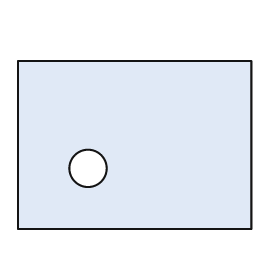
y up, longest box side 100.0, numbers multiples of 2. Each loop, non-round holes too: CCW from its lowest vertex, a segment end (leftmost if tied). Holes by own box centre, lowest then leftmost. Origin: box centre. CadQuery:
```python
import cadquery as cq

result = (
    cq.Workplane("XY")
    .moveTo(-50.0, -36.0)
    .lineTo(50.0, -36.0)
    .lineTo(50.0, 36.0)
    .lineTo(-50.0, 36.0)
    .close()
    .moveTo(-20.0, -10.0)
    .circle(8.0)
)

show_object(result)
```